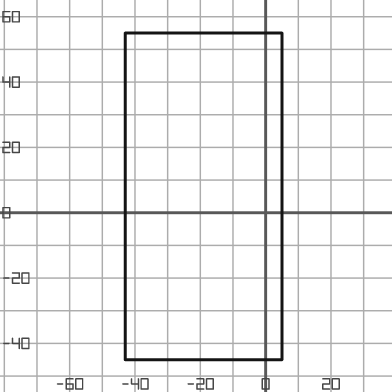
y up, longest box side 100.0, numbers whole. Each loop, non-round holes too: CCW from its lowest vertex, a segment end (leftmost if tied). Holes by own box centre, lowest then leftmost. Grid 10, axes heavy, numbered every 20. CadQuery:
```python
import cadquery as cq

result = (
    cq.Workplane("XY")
    .moveTo(-43.0, -45.0)
    .lineTo(5.0, -45.0)
    .lineTo(5.0, 55.0)
    .lineTo(-43.0, 55.0)
    .close()
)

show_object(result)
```